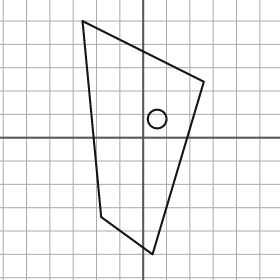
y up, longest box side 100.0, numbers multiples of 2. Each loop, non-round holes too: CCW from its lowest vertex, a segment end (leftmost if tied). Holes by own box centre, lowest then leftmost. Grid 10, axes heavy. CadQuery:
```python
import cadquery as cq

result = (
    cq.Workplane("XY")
    .moveTo(4.0, -50.0)
    .lineTo(26.0, 24.0)
    .lineTo(-26.0, 50.0)
    .lineTo(-18.0, -34.0)
    .close()
    .moveTo(6.0, 8.0)
    .circle(4.0)
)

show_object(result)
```